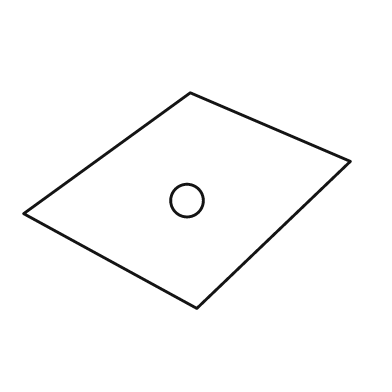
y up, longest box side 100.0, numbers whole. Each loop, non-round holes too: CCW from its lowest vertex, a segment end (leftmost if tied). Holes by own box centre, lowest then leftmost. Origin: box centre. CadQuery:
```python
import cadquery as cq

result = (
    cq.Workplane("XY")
    .moveTo(3.0, -33.0)
    .lineTo(50.0, 12.0)
    .lineTo(1.0, 33.0)
    .lineTo(-50.0, -4.0)
    .close()
    .moveTo(0.0, 0.0)
    .circle(5.0)
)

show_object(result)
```